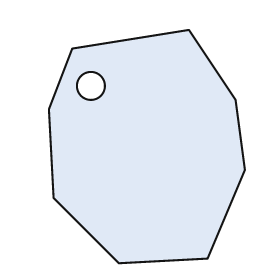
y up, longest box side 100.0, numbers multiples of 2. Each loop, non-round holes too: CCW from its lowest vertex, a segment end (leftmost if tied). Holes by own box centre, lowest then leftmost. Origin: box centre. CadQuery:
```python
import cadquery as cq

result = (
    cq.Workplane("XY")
    .moveTo(-12.0, -50.0)
    .lineTo(26.0, -48.0)
    .lineTo(42.0, -10.0)
    .lineTo(38.0, 20.0)
    .lineTo(18.0, 50.0)
    .lineTo(-32.0, 42.0)
    .lineTo(-42.0, 16.0)
    .lineTo(-40.0, -22.0)
    .close()
    .moveTo(-24.0, 26.0)
    .circle(6.0)
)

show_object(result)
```